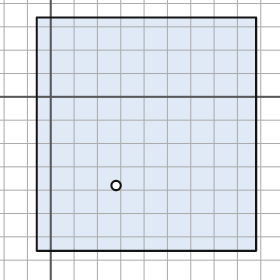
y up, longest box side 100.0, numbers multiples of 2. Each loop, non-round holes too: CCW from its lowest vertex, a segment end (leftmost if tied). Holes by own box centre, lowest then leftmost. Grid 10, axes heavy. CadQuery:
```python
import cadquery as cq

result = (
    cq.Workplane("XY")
    .moveTo(-6.0, -66.0)
    .lineTo(88.0, -66.0)
    .lineTo(88.0, 34.0)
    .lineTo(-6.0, 34.0)
    .close()
    .moveTo(28.0, -38.0)
    .circle(2.0)
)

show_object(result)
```